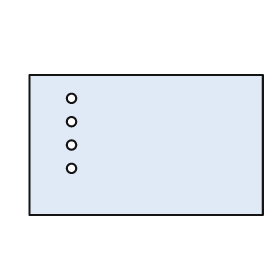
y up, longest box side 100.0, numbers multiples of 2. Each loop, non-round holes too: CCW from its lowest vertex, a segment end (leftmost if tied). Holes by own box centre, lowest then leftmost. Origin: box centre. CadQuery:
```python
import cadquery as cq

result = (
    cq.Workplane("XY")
    .moveTo(-50.0, -30.0)
    .lineTo(50.0, -30.0)
    .lineTo(50.0, 30.0)
    .lineTo(-50.0, 30.0)
    .close()
    .moveTo(-32.0, -10.0)
    .circle(2.0)
    .moveTo(-32.0, 0.0)
    .circle(2.0)
    .moveTo(-32.0, 10.0)
    .circle(2.0)
    .moveTo(-32.0, 20.0)
    .circle(2.0)
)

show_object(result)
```